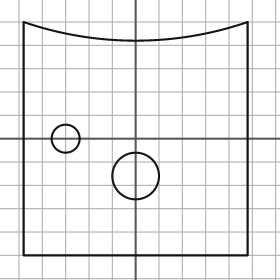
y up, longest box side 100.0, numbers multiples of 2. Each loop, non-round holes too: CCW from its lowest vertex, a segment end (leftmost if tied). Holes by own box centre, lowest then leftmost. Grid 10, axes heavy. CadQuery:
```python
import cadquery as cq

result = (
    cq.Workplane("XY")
    .moveTo(-48.0, -50.0)
    .lineTo(48.0, -50.0)
    .lineTo(48.0, 50.0)
    .threePointArc((0.0, 42.0), (-48.0, 50.0))
    .close()
    .moveTo(0.0, -16.0)
    .circle(10.0)
    .moveTo(-30.0, 0.0)
    .circle(6.0)
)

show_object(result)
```